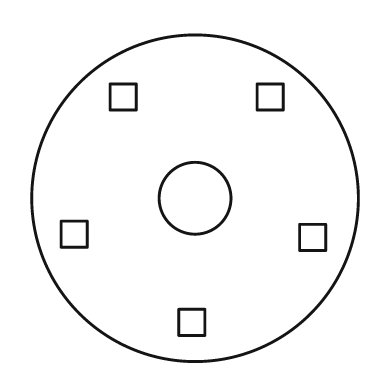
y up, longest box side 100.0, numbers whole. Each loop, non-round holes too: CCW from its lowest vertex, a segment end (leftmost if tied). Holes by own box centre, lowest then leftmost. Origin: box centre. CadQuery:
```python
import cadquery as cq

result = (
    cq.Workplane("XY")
    .moveTo(0.0, 0.0)
    .circle(50.0)
    .moveTo(-5.0, -42.0)
    .lineTo(3.0, -42.0)
    .lineTo(3.0, -34.0)
    .lineTo(-5.0, -34.0)
    .close()
    .moveTo(32.0, -16.0)
    .lineTo(40.0, -16.0)
    .lineTo(40.0, -8.0)
    .lineTo(32.0, -8.0)
    .close()
    .moveTo(-41.0, -15.0)
    .lineTo(-33.0, -15.0)
    .lineTo(-33.0, -7.0)
    .lineTo(-41.0, -7.0)
    .close()
    .moveTo(0.0, 0.0)
    .circle(11.0)
    .moveTo(-26.0, 27.0)
    .lineTo(-18.0, 27.0)
    .lineTo(-18.0, 35.0)
    .lineTo(-26.0, 35.0)
    .close()
    .moveTo(19.0, 27.0)
    .lineTo(27.0, 27.0)
    .lineTo(27.0, 35.0)
    .lineTo(19.0, 35.0)
    .close()
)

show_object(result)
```